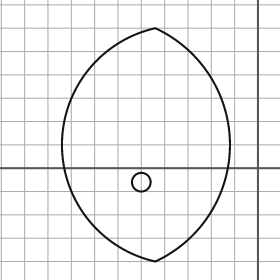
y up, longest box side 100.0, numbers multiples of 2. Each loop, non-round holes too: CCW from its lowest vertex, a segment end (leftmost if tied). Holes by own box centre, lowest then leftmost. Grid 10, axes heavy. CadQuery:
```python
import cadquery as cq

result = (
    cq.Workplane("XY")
    .moveTo(-44.0, -40.0)
    .threePointArc((-12.0, 10.0), (-44.0, 60.0))
    .threePointArc((-84.0, 10.0), (-44.0, -40.0))
    .close()
    .moveTo(-50.0, -6.0)
    .circle(4.0)
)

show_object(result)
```